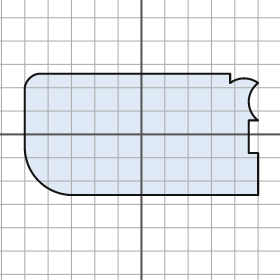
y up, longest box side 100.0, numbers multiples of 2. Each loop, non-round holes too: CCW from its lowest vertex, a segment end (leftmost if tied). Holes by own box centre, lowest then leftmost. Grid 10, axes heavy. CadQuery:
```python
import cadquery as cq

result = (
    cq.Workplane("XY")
    .moveTo(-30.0, -26.0)
    .lineTo(50.0, -26.0)
    .lineTo(50.0, -8.0)
    .lineTo(46.0, -8.0)
    .lineTo(46.0, 6.0)
    .lineTo(50.0, 6.0)
    .threePointArc((46.0, 14.0), (50.0, 22.0))
    .threePointArc((44.0, 24.0), (38.0, 22.0))
    .lineTo(38.0, 26.0)
    .lineTo(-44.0, 26.0)
    .threePointArc((-48.0, 24.0), (-50.0, 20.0))
    .lineTo(-50.0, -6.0)
    .threePointArc((-44.0, -20.0), (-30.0, -26.0))
    .close()
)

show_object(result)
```